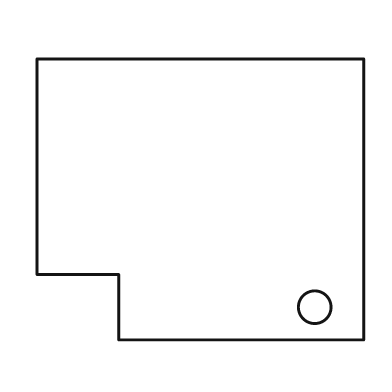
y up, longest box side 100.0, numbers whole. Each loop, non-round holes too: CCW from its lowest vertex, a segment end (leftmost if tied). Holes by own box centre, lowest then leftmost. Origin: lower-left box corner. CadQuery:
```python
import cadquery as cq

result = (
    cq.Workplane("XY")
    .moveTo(25.0, 0.0)
    .lineTo(100.0, 0.0)
    .lineTo(100.0, 86.0)
    .lineTo(0.0, 86.0)
    .lineTo(0.0, 20.0)
    .lineTo(25.0, 20.0)
    .close()
    .moveTo(85.0, 10.0)
    .circle(5.0)
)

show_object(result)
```